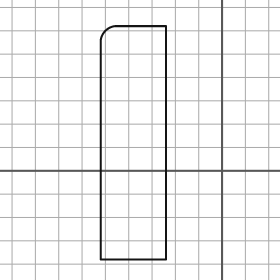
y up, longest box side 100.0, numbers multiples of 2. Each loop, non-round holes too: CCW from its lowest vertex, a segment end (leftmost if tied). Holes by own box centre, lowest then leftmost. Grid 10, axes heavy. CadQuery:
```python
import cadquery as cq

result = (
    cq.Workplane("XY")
    .moveTo(-52.0, -38.0)
    .lineTo(-24.0, -38.0)
    .lineTo(-24.0, 62.0)
    .lineTo(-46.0, 62.0)
    .threePointArc((-50.0, 60.0), (-52.0, 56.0))
    .close()
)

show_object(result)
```